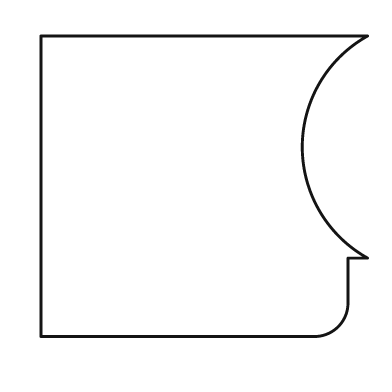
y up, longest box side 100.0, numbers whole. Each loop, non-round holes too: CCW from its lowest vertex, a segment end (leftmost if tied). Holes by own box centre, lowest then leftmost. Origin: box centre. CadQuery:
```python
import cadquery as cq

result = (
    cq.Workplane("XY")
    .moveTo(-50.0, -46.0)
    .lineTo(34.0, -46.0)
    .threePointArc((41.0, -43.0), (44.0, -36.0))
    .lineTo(44.0, -22.0)
    .lineTo(50.0, -22.0)
    .threePointArc((30.0, 12.0), (50.0, 46.0))
    .lineTo(-50.0, 46.0)
    .close()
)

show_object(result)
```